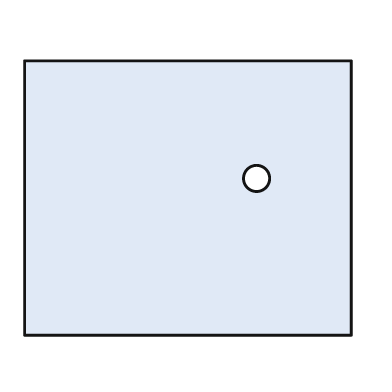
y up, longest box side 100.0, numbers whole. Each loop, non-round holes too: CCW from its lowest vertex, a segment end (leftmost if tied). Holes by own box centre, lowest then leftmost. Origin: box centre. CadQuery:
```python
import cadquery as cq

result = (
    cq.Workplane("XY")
    .moveTo(-50.0, -42.0)
    .lineTo(50.0, -42.0)
    .lineTo(50.0, 42.0)
    .lineTo(-50.0, 42.0)
    .close()
    .moveTo(21.0, 6.0)
    .circle(4.0)
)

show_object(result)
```